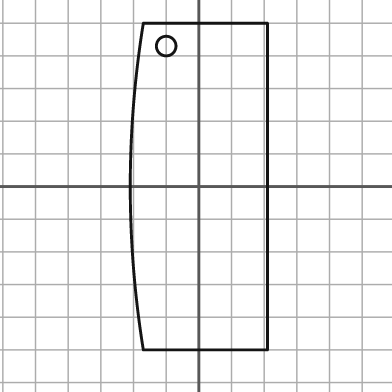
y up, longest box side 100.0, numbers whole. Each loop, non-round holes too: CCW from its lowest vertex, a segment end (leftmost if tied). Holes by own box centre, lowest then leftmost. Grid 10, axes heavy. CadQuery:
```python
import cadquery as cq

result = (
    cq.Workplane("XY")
    .moveTo(-17.0, -50.0)
    .lineTo(21.0, -50.0)
    .lineTo(21.0, 50.0)
    .lineTo(-17.0, 50.0)
    .threePointArc((-21.0, 0.0), (-17.0, -50.0))
    .close()
    .moveTo(-10.0, 43.0)
    .circle(3.0)
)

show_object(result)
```